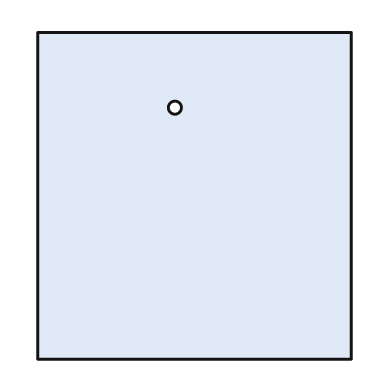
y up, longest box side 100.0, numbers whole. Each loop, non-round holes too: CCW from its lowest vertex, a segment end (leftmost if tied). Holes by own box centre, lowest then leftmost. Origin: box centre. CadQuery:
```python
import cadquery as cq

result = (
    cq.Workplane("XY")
    .moveTo(-48.0, -50.0)
    .lineTo(48.0, -50.0)
    .lineTo(48.0, 50.0)
    .lineTo(-48.0, 50.0)
    .close()
    .moveTo(-6.0, 27.0)
    .circle(2.0)
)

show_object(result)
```